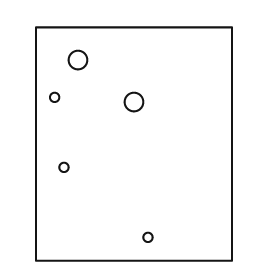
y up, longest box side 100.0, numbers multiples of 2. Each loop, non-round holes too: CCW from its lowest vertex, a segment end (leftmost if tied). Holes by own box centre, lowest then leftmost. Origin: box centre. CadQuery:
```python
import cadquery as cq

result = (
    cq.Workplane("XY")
    .moveTo(-42.0, -50.0)
    .lineTo(42.0, -50.0)
    .lineTo(42.0, 50.0)
    .lineTo(-42.0, 50.0)
    .close()
    .moveTo(6.0, -40.0)
    .circle(2.0)
    .moveTo(-30.0, -10.0)
    .circle(2.0)
    .moveTo(0.0, 18.0)
    .circle(4.0)
    .moveTo(-34.0, 20.0)
    .circle(2.0)
    .moveTo(-24.0, 36.0)
    .circle(4.0)
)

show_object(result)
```